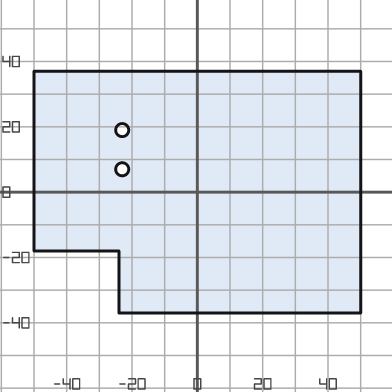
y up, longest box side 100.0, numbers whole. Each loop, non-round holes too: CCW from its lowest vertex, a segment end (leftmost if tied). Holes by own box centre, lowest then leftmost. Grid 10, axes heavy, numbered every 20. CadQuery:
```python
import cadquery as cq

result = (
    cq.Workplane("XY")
    .moveTo(-24.0, -37.0)
    .lineTo(50.0, -37.0)
    .lineTo(50.0, 37.0)
    .lineTo(-50.0, 37.0)
    .lineTo(-50.0, -18.0)
    .lineTo(-24.0, -18.0)
    .close()
    .moveTo(-23.0, 7.0)
    .circle(2.0)
    .moveTo(-23.0, 19.0)
    .circle(2.0)
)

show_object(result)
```